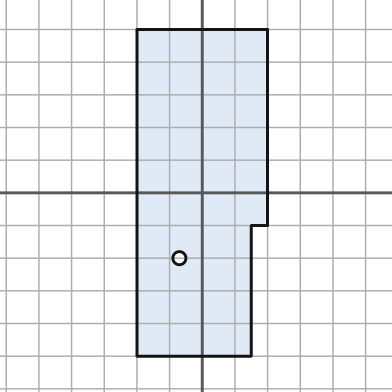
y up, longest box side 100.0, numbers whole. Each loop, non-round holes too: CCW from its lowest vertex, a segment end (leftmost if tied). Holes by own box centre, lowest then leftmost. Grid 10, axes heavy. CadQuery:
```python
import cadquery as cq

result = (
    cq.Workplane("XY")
    .moveTo(-20.0, -50.0)
    .lineTo(15.0, -50.0)
    .lineTo(15.0, -10.0)
    .lineTo(20.0, -10.0)
    .lineTo(20.0, 50.0)
    .lineTo(-20.0, 50.0)
    .close()
    .moveTo(-7.0, -20.0)
    .circle(2.0)
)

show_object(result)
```